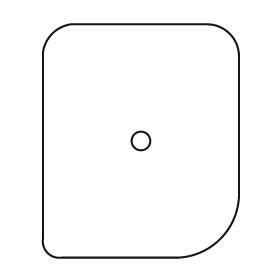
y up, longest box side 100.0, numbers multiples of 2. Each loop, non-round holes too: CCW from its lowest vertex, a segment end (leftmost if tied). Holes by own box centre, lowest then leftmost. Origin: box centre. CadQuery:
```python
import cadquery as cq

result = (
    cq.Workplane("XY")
    .moveTo(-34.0, -50.0)
    .lineTo(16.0, -50.0)
    .threePointArc((34.0, -42.0), (42.0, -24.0))
    .lineTo(42.0, 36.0)
    .threePointArc((38.0, 46.0), (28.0, 50.0))
    .lineTo(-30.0, 50.0)
    .threePointArc((-38.0, 46.0), (-42.0, 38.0))
    .lineTo(-42.0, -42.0)
    .threePointArc((-40.0, -48.0), (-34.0, -50.0))
    .close()
    .moveTo(0.0, 0.0)
    .circle(4.0)
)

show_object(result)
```